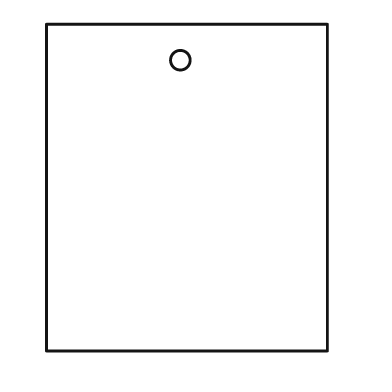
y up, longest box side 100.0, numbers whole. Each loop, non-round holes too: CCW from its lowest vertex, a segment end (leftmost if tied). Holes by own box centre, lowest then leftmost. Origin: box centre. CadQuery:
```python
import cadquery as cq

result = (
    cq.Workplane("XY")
    .moveTo(-43.0, -50.0)
    .lineTo(43.0, -50.0)
    .lineTo(43.0, 50.0)
    .lineTo(-43.0, 50.0)
    .close()
    .moveTo(-2.0, 39.0)
    .circle(3.0)
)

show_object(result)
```